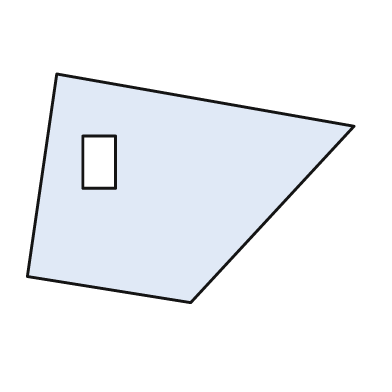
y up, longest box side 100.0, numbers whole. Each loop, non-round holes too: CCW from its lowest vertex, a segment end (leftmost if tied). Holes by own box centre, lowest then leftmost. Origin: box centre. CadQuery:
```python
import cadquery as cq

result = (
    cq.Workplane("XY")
    .moveTo(0.0, -35.0)
    .lineTo(50.0, 19.0)
    .lineTo(-41.0, 35.0)
    .lineTo(-50.0, -27.0)
    .close()
    .moveTo(-33.0, 0.0)
    .lineTo(-23.0, 0.0)
    .lineTo(-23.0, 16.0)
    .lineTo(-33.0, 16.0)
    .close()
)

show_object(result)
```